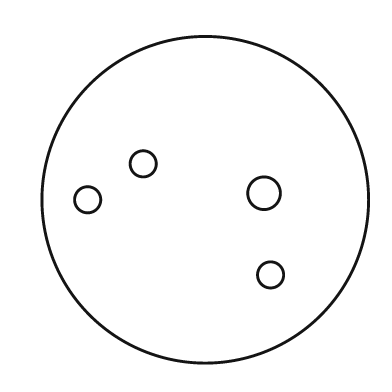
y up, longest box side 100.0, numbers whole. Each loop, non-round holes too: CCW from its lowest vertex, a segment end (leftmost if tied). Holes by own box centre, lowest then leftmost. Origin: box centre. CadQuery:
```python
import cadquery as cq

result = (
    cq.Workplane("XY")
    .moveTo(0.0, 0.0)
    .circle(50.0)
    .moveTo(20.0, -23.0)
    .circle(4.0)
    .moveTo(-36.0, 0.0)
    .circle(4.0)
    .moveTo(18.0, 2.0)
    .circle(5.0)
    .moveTo(-19.0, 11.0)
    .circle(4.0)
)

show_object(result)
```